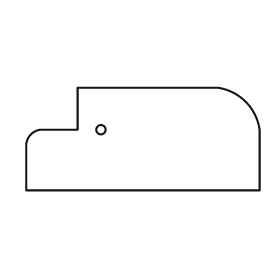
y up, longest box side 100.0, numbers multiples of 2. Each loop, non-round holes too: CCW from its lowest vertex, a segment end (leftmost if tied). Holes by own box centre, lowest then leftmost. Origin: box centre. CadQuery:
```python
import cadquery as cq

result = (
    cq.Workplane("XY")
    .moveTo(-50.0, -22.0)
    .lineTo(50.0, -22.0)
    .lineTo(50.0, 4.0)
    .threePointArc((44.0, 16.0), (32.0, 22.0))
    .lineTo(-28.0, 22.0)
    .lineTo(-28.0, 4.0)
    .lineTo(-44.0, 4.0)
    .threePointArc((-48.0, 2.0), (-50.0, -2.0))
    .close()
    .moveTo(-18.0, 4.0)
    .circle(2.0)
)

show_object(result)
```